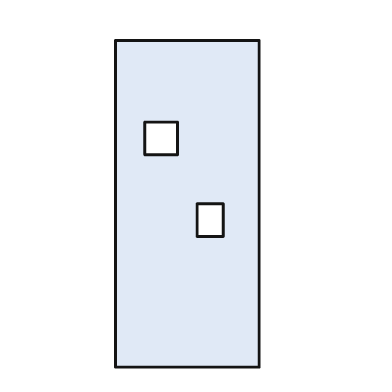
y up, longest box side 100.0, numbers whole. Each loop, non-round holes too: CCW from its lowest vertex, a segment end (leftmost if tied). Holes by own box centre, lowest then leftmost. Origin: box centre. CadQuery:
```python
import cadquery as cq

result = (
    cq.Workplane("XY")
    .moveTo(-22.0, -50.0)
    .lineTo(22.0, -50.0)
    .lineTo(22.0, 50.0)
    .lineTo(-22.0, 50.0)
    .close()
    .moveTo(3.0, -10.0)
    .lineTo(11.0, -10.0)
    .lineTo(11.0, 0.0)
    .lineTo(3.0, 0.0)
    .close()
    .moveTo(-13.0, 15.0)
    .lineTo(-3.0, 15.0)
    .lineTo(-3.0, 25.0)
    .lineTo(-13.0, 25.0)
    .close()
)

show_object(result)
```